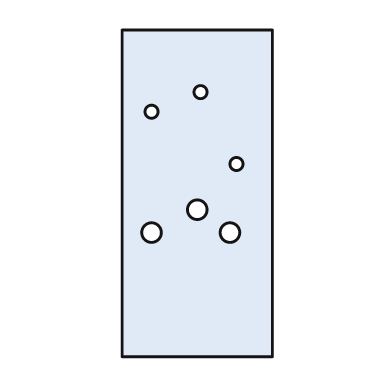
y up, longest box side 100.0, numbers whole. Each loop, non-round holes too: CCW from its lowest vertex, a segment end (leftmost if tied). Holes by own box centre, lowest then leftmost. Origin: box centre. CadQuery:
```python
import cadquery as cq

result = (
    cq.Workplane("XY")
    .moveTo(-23.0, -50.0)
    .lineTo(23.0, -50.0)
    .lineTo(23.0, 50.0)
    .lineTo(-23.0, 50.0)
    .close()
    .moveTo(-14.0, -12.0)
    .circle(3.0)
    .moveTo(10.0, -12.0)
    .circle(3.0)
    .moveTo(0.0, -5.0)
    .circle(3.0)
    .moveTo(12.0, 9.0)
    .circle(2.0)
    .moveTo(-14.0, 25.0)
    .circle(2.0)
    .moveTo(1.0, 31.0)
    .circle(2.0)
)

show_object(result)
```